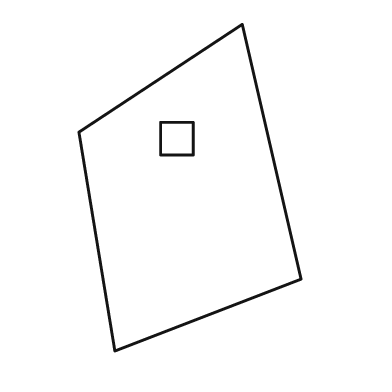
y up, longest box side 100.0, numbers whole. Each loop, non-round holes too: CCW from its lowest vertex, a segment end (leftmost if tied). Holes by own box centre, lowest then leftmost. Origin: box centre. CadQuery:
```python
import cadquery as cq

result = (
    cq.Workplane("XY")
    .moveTo(-23.0, -50.0)
    .lineTo(34.0, -28.0)
    .lineTo(16.0, 50.0)
    .lineTo(-34.0, 17.0)
    .close()
    .moveTo(-9.0, 10.0)
    .lineTo(1.0, 10.0)
    .lineTo(1.0, 20.0)
    .lineTo(-9.0, 20.0)
    .close()
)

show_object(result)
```